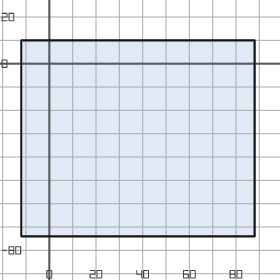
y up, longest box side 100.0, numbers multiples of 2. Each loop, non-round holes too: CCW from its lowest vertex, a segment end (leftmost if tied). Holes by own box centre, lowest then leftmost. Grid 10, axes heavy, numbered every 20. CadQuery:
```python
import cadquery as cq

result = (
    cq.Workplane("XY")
    .moveTo(-12.0, -74.0)
    .lineTo(88.0, -74.0)
    .lineTo(88.0, 10.0)
    .lineTo(-12.0, 10.0)
    .close()
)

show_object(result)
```